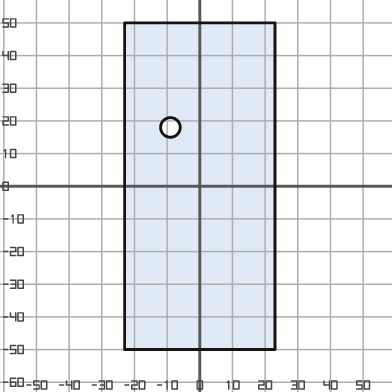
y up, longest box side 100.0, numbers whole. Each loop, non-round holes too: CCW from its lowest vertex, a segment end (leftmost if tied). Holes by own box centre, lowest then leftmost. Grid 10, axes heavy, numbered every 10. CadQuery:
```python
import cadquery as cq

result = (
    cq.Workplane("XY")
    .moveTo(-23.0, -50.0)
    .lineTo(23.0, -50.0)
    .lineTo(23.0, 50.0)
    .lineTo(-23.0, 50.0)
    .close()
    .moveTo(-9.0, 18.0)
    .circle(3.0)
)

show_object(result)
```